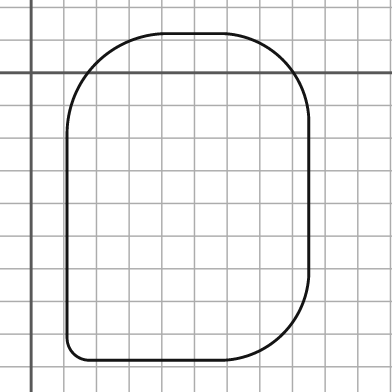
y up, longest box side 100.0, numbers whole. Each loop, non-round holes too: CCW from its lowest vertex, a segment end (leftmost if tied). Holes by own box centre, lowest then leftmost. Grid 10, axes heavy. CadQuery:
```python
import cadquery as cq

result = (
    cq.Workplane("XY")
    .moveTo(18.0, -88.0)
    .lineTo(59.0, -88.0)
    .threePointArc((77.0, -80.0), (85.0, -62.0))
    .lineTo(85.0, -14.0)
    .threePointArc((77.0, 4.0), (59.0, 12.0))
    .lineTo(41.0, 12.0)
    .threePointArc((20.0, 3.0), (11.0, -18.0))
    .lineTo(11.0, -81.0)
    .threePointArc((13.0, -86.0), (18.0, -88.0))
    .close()
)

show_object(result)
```